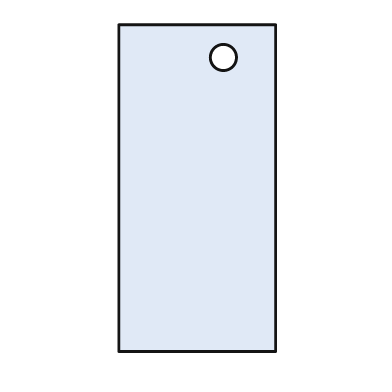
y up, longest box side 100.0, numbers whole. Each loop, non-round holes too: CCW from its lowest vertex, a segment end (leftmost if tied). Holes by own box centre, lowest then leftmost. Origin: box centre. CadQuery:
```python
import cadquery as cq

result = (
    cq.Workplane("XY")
    .moveTo(-24.0, -50.0)
    .lineTo(24.0, -50.0)
    .lineTo(24.0, 50.0)
    .lineTo(-24.0, 50.0)
    .close()
    .moveTo(8.0, 40.0)
    .circle(4.0)
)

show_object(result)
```